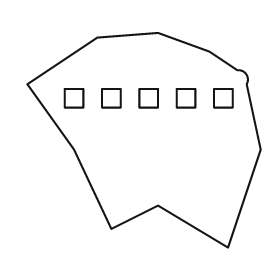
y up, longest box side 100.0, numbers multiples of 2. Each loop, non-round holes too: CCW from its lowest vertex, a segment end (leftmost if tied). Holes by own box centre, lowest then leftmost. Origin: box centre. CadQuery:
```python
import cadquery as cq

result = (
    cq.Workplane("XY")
    .moveTo(36.0, -46.0)
    .lineTo(50.0, -4.0)
    .lineTo(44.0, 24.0)
    .threePointArc((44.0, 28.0), (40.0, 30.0))
    .lineTo(28.0, 38.0)
    .lineTo(6.0, 46.0)
    .lineTo(-20.0, 44.0)
    .lineTo(-50.0, 24.0)
    .lineTo(-30.0, -4.0)
    .lineTo(-14.0, -38.0)
    .lineTo(6.0, -28.0)
    .close()
    .moveTo(-34.0, 14.0)
    .lineTo(-26.0, 14.0)
    .lineTo(-26.0, 22.0)
    .lineTo(-34.0, 22.0)
    .close()
    .moveTo(-18.0, 14.0)
    .lineTo(-10.0, 14.0)
    .lineTo(-10.0, 22.0)
    .lineTo(-18.0, 22.0)
    .close()
    .moveTo(-2.0, 14.0)
    .lineTo(6.0, 14.0)
    .lineTo(6.0, 22.0)
    .lineTo(-2.0, 22.0)
    .close()
    .moveTo(14.0, 14.0)
    .lineTo(22.0, 14.0)
    .lineTo(22.0, 22.0)
    .lineTo(14.0, 22.0)
    .close()
    .moveTo(30.0, 14.0)
    .lineTo(38.0, 14.0)
    .lineTo(38.0, 22.0)
    .lineTo(30.0, 22.0)
    .close()
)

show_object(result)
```